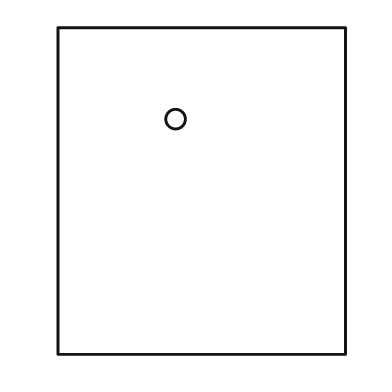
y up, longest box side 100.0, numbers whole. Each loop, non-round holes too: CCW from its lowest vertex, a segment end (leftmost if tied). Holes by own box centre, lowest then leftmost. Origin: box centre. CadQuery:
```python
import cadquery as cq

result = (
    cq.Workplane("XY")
    .moveTo(-44.0, -50.0)
    .lineTo(44.0, -50.0)
    .lineTo(44.0, 50.0)
    .lineTo(-44.0, 50.0)
    .close()
    .moveTo(-8.0, 22.0)
    .circle(3.0)
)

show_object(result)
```